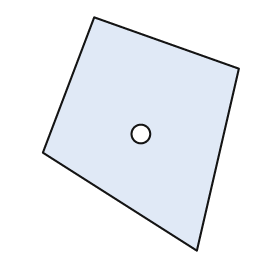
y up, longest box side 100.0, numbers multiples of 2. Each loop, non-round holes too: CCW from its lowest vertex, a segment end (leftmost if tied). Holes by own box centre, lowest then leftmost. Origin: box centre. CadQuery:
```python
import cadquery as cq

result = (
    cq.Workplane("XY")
    .moveTo(24.0, -50.0)
    .lineTo(42.0, 28.0)
    .lineTo(-20.0, 50.0)
    .lineTo(-42.0, -8.0)
    .close()
    .moveTo(0.0, 0.0)
    .circle(4.0)
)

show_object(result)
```